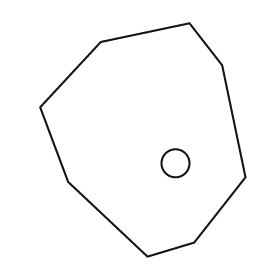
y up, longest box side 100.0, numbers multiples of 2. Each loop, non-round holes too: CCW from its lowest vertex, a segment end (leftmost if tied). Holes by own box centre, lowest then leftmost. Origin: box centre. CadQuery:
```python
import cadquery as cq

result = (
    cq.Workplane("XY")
    .moveTo(2.0, -50.0)
    .lineTo(22.0, -44.0)
    .lineTo(44.0, -16.0)
    .lineTo(34.0, 32.0)
    .lineTo(20.0, 50.0)
    .lineTo(-18.0, 42.0)
    .lineTo(-44.0, 14.0)
    .lineTo(-32.0, -18.0)
    .close()
    .moveTo(14.0, -10.0)
    .circle(6.0)
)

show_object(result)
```